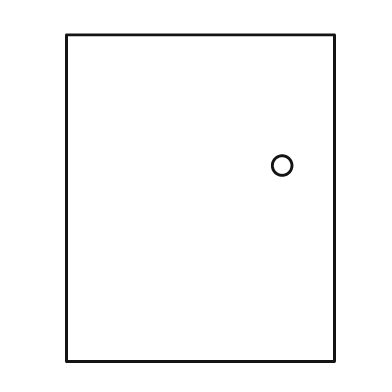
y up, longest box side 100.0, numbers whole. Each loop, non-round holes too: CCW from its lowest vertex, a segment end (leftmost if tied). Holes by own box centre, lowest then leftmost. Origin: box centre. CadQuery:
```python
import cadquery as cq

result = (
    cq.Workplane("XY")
    .moveTo(-41.0, -50.0)
    .lineTo(41.0, -50.0)
    .lineTo(41.0, 50.0)
    .lineTo(-41.0, 50.0)
    .close()
    .moveTo(25.0, 10.0)
    .circle(3.0)
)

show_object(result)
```